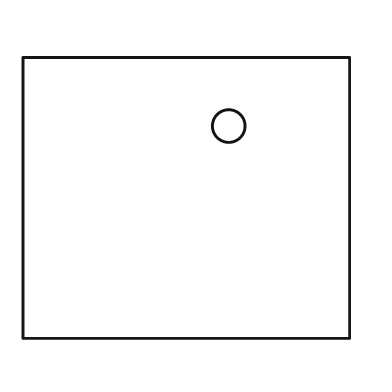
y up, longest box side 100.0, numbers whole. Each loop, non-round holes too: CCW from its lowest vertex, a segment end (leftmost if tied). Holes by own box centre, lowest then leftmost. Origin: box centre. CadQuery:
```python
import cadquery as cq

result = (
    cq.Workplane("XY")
    .moveTo(-50.0, -43.0)
    .lineTo(50.0, -43.0)
    .lineTo(50.0, 43.0)
    .lineTo(-50.0, 43.0)
    .close()
    .moveTo(13.0, 22.0)
    .circle(5.0)
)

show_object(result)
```